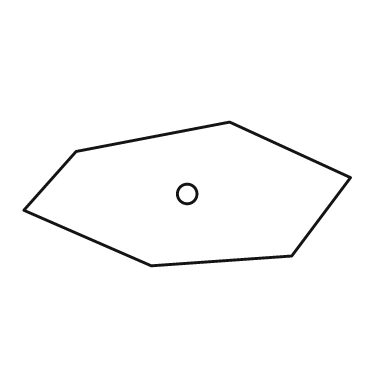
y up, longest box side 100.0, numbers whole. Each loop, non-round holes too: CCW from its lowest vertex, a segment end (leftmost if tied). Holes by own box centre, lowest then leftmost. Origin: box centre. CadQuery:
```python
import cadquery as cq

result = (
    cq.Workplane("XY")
    .moveTo(-11.0, -22.0)
    .lineTo(32.0, -19.0)
    .lineTo(50.0, 5.0)
    .lineTo(13.0, 22.0)
    .lineTo(-34.0, 13.0)
    .lineTo(-50.0, -5.0)
    .close()
    .moveTo(0.0, 0.0)
    .circle(3.0)
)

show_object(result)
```